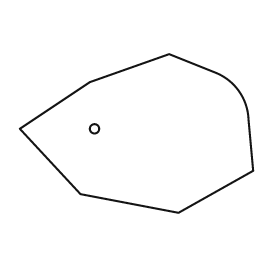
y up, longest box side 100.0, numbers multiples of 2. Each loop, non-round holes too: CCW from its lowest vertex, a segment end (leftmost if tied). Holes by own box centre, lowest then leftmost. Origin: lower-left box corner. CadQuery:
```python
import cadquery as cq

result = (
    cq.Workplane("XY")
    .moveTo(68.0, 0.0)
    .lineTo(100.0, 18.0)
    .lineTo(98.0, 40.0)
    .threePointArc((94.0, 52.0), (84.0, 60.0))
    .lineTo(64.0, 68.0)
    .lineTo(30.0, 56.0)
    .lineTo(0.0, 36.0)
    .lineTo(26.0, 8.0)
    .close()
    .moveTo(32.0, 36.0)
    .circle(2.0)
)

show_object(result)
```